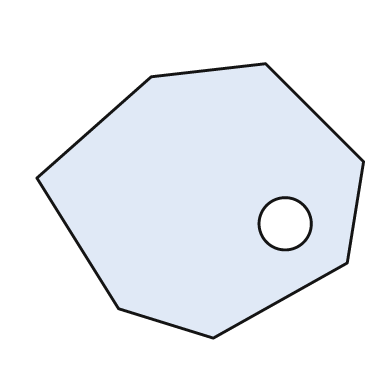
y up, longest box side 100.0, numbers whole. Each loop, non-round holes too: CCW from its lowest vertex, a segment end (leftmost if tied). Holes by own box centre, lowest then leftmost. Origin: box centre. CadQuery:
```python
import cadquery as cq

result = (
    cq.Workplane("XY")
    .moveTo(4.0, -42.0)
    .lineTo(45.0, -19.0)
    .lineTo(50.0, 12.0)
    .lineTo(20.0, 42.0)
    .lineTo(-15.0, 38.0)
    .lineTo(-50.0, 7.0)
    .lineTo(-25.0, -33.0)
    .close()
    .moveTo(26.0, -7.0)
    .circle(8.0)
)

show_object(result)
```